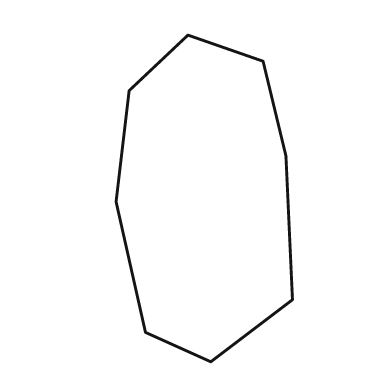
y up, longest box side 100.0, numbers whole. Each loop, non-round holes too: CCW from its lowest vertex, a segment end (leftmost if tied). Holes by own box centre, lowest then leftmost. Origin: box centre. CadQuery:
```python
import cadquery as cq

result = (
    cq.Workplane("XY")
    .moveTo(2.0, -50.0)
    .lineTo(27.0, -31.0)
    .lineTo(25.0, 13.0)
    .lineTo(18.0, 42.0)
    .lineTo(-5.0, 50.0)
    .lineTo(-23.0, 33.0)
    .lineTo(-27.0, -1.0)
    .lineTo(-18.0, -41.0)
    .close()
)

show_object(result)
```